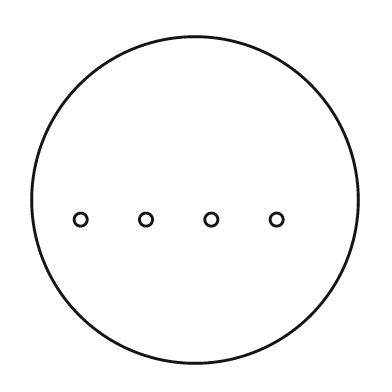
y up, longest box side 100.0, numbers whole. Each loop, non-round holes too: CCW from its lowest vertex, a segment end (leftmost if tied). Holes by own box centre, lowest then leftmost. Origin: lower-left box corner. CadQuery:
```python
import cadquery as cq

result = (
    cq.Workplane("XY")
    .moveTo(50.0, 50.0)
    .circle(50.0)
    .moveTo(15.0, 44.0)
    .circle(2.0)
    .moveTo(35.0, 44.0)
    .circle(2.0)
    .moveTo(55.0, 44.0)
    .circle(2.0)
    .moveTo(75.0, 44.0)
    .circle(2.0)
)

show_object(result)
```